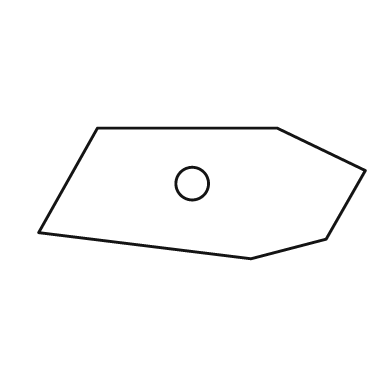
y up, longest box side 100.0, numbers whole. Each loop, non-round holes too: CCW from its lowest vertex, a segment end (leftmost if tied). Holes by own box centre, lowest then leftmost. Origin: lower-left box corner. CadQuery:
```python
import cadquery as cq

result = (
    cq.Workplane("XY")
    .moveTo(65.0, 0.0)
    .lineTo(88.0, 6.0)
    .lineTo(100.0, 27.0)
    .lineTo(73.0, 40.0)
    .lineTo(18.0, 40.0)
    .lineTo(0.0, 8.0)
    .close()
    .moveTo(47.0, 23.0)
    .circle(5.0)
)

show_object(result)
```